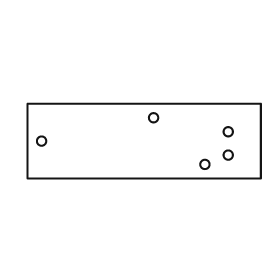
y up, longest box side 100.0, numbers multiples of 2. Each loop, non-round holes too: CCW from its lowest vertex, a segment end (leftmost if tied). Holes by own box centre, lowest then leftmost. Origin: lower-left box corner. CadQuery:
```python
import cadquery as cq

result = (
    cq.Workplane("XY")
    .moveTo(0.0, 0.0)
    .lineTo(100.0, 0.0)
    .lineTo(100.0, 32.0)
    .lineTo(0.0, 32.0)
    .close()
    .moveTo(76.0, 6.0)
    .circle(2.0)
    .moveTo(86.0, 10.0)
    .circle(2.0)
    .moveTo(6.0, 16.0)
    .circle(2.0)
    .moveTo(86.0, 20.0)
    .circle(2.0)
    .moveTo(54.0, 26.0)
    .circle(2.0)
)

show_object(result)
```